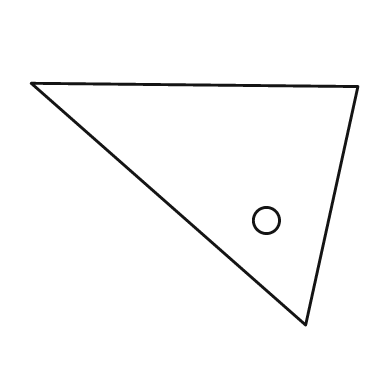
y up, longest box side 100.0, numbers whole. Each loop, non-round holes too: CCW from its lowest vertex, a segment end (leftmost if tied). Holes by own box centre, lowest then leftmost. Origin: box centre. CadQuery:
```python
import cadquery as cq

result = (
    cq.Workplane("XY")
    .moveTo(34.0, -37.0)
    .lineTo(50.0, 36.0)
    .lineTo(-50.0, 37.0)
    .close()
    .moveTo(22.0, -5.0)
    .circle(4.0)
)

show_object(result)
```